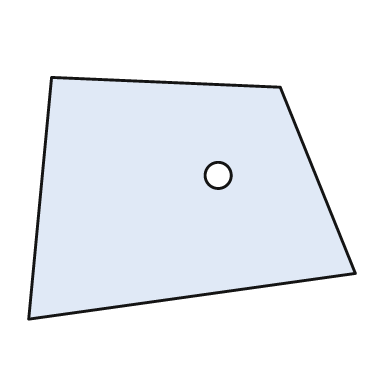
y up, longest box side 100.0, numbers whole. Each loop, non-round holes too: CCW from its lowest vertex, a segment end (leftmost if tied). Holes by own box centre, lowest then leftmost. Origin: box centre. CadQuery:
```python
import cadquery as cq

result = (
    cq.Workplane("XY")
    .moveTo(-50.0, -37.0)
    .lineTo(50.0, -23.0)
    .lineTo(27.0, 34.0)
    .lineTo(-43.0, 37.0)
    .close()
    .moveTo(8.0, 7.0)
    .circle(4.0)
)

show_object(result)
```